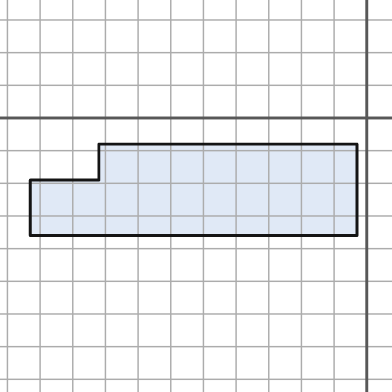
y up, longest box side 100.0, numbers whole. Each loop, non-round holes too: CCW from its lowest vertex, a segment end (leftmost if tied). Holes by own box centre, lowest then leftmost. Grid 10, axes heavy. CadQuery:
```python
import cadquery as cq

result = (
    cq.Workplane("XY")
    .moveTo(-103.0, -36.0)
    .lineTo(-3.0, -36.0)
    .lineTo(-3.0, -8.0)
    .lineTo(-82.0, -8.0)
    .lineTo(-82.0, -19.0)
    .lineTo(-103.0, -19.0)
    .close()
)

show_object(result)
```